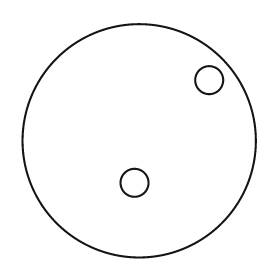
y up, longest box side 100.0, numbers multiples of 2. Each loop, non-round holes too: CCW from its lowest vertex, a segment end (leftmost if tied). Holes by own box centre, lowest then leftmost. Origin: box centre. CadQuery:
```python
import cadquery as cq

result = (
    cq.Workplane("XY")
    .moveTo(0.0, 0.0)
    .circle(50.0)
    .moveTo(-2.0, -18.0)
    .circle(6.0)
    .moveTo(30.0, 26.0)
    .circle(6.0)
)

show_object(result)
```